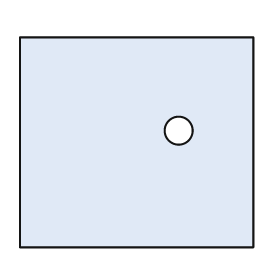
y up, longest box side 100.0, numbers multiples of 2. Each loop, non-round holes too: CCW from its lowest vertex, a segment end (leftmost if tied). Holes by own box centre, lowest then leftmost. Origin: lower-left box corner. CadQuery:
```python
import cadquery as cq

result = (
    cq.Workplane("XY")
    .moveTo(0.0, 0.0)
    .lineTo(100.0, 0.0)
    .lineTo(100.0, 90.0)
    .lineTo(0.0, 90.0)
    .close()
    .moveTo(68.0, 50.0)
    .circle(6.0)
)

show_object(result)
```